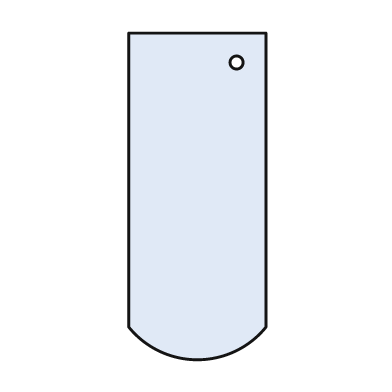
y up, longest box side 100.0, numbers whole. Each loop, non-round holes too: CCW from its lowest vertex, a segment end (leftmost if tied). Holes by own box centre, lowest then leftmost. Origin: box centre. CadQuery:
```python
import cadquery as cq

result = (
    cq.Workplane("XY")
    .moveTo(-21.0, -40.0)
    .threePointArc((0.0, -50.0), (21.0, -40.0))
    .lineTo(21.0, 50.0)
    .lineTo(-21.0, 50.0)
    .close()
    .moveTo(12.0, 41.0)
    .circle(2.0)
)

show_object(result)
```